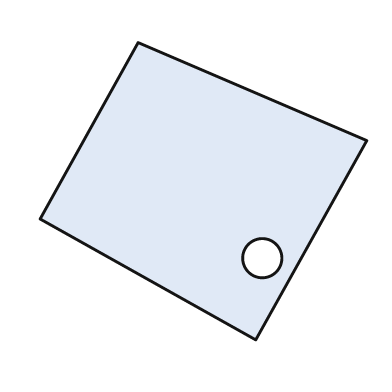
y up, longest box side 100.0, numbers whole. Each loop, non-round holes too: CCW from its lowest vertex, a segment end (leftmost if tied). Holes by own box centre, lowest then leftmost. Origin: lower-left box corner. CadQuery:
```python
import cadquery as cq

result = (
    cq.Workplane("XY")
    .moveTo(66.0, 0.0)
    .lineTo(100.0, 61.0)
    .lineTo(30.0, 91.0)
    .lineTo(0.0, 37.0)
    .close()
    .moveTo(68.0, 25.0)
    .circle(6.0)
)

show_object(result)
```